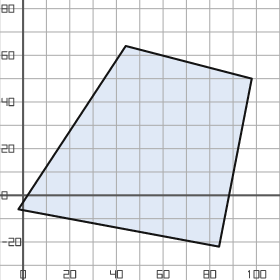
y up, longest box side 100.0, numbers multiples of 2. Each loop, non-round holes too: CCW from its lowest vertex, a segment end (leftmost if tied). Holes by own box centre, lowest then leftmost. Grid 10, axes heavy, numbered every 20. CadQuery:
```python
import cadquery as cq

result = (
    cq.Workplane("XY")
    .moveTo(84.0, -22.0)
    .lineTo(98.0, 50.0)
    .lineTo(44.0, 64.0)
    .lineTo(-2.0, -6.0)
    .close()
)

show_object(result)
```